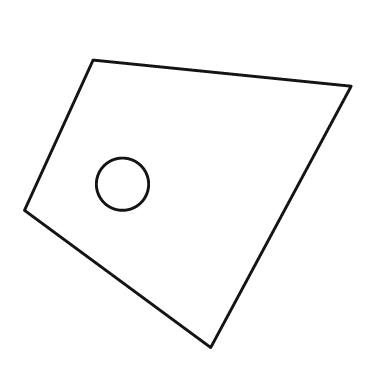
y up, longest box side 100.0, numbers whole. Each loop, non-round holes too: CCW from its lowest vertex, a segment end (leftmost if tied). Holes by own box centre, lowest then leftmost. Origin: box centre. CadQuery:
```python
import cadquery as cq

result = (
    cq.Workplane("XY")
    .moveTo(7.0, -44.0)
    .lineTo(50.0, 36.0)
    .lineTo(-29.0, 44.0)
    .lineTo(-50.0, -2.0)
    .close()
    .moveTo(-20.0, 6.0)
    .circle(8.0)
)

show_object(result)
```